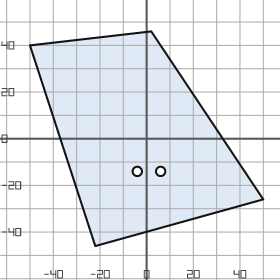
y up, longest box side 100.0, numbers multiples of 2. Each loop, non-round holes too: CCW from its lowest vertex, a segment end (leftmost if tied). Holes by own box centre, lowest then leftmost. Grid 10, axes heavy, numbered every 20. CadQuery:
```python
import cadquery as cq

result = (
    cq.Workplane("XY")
    .moveTo(-22.0, -46.0)
    .lineTo(50.0, -26.0)
    .lineTo(2.0, 46.0)
    .lineTo(-50.0, 40.0)
    .close()
    .moveTo(-4.0, -14.0)
    .circle(2.0)
    .moveTo(6.0, -14.0)
    .circle(2.0)
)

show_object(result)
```